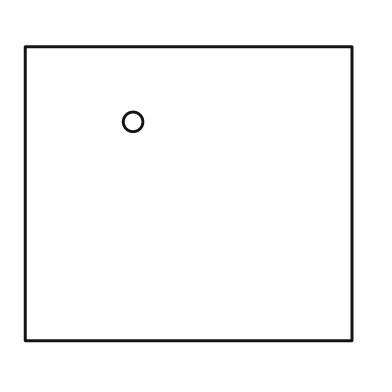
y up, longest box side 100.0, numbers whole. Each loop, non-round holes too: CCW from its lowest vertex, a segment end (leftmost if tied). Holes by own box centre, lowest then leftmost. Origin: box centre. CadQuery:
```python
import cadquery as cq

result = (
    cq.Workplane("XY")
    .moveTo(-50.0, -45.0)
    .lineTo(50.0, -45.0)
    .lineTo(50.0, 45.0)
    .lineTo(-50.0, 45.0)
    .close()
    .moveTo(-17.0, 22.0)
    .circle(3.0)
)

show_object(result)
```